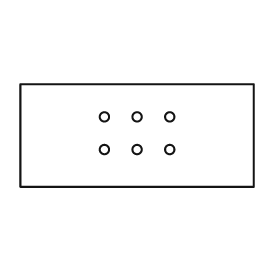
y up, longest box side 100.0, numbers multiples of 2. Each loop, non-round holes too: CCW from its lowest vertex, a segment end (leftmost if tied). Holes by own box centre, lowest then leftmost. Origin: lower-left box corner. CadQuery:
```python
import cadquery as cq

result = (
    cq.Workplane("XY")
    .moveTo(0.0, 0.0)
    .lineTo(100.0, 0.0)
    .lineTo(100.0, 44.0)
    .lineTo(0.0, 44.0)
    .close()
    .moveTo(36.0, 16.0)
    .circle(2.0)
    .moveTo(50.0, 16.0)
    .circle(2.0)
    .moveTo(64.0, 16.0)
    .circle(2.0)
    .moveTo(36.0, 30.0)
    .circle(2.0)
    .moveTo(50.0, 30.0)
    .circle(2.0)
    .moveTo(64.0, 30.0)
    .circle(2.0)
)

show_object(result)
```